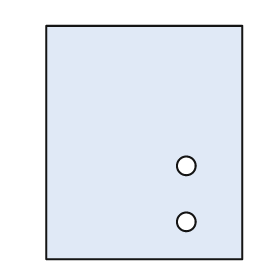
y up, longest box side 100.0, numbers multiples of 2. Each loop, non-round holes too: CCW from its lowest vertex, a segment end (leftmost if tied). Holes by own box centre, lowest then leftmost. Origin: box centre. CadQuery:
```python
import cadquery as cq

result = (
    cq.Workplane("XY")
    .moveTo(-42.0, -50.0)
    .lineTo(42.0, -50.0)
    .lineTo(42.0, 50.0)
    .lineTo(-42.0, 50.0)
    .close()
    .moveTo(18.0, -34.0)
    .circle(4.0)
    .moveTo(18.0, -10.0)
    .circle(4.0)
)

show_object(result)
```